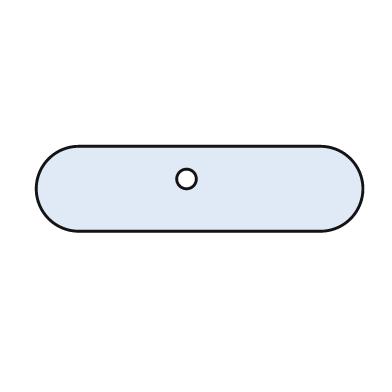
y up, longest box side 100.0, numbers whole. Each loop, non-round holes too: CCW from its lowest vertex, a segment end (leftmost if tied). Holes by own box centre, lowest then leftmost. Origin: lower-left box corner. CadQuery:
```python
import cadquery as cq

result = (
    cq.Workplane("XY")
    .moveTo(13.0, 0.0)
    .lineTo(87.0, 0.0)
    .threePointArc((100.0, 13.0), (87.0, 26.0))
    .lineTo(13.0, 26.0)
    .threePointArc((0.0, 13.0), (13.0, 0.0))
    .close()
    .moveTo(46.0, 16.0)
    .circle(3.0)
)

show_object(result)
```